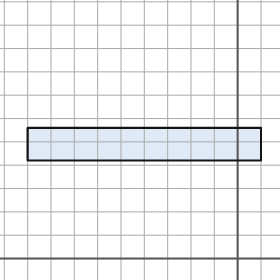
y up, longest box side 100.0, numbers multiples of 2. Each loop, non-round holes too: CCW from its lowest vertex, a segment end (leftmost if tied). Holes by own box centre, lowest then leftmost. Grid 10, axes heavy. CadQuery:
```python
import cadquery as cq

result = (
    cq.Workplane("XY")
    .moveTo(-90.0, 42.0)
    .lineTo(10.0, 42.0)
    .lineTo(10.0, 56.0)
    .lineTo(-90.0, 56.0)
    .close()
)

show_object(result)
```